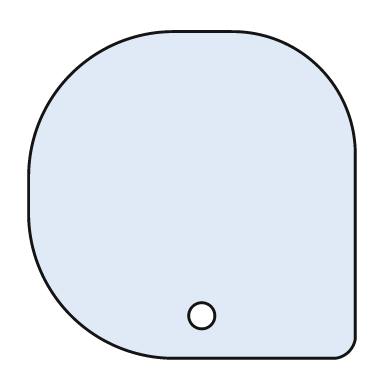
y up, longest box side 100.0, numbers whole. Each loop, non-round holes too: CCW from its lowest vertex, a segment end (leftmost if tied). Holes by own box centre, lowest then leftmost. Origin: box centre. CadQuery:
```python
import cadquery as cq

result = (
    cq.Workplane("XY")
    .moveTo(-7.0, -50.0)
    .lineTo(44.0, -50.0)
    .threePointArc((48.0, -48.0), (50.0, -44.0))
    .lineTo(50.0, 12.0)
    .threePointArc((39.0, 39.0), (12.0, 50.0))
    .lineTo(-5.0, 50.0)
    .threePointArc((-37.0, 37.0), (-50.0, 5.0))
    .lineTo(-50.0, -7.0)
    .threePointArc((-37.0, -37.0), (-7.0, -50.0))
    .close()
    .moveTo(3.0, -37.0)
    .circle(4.0)
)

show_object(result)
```